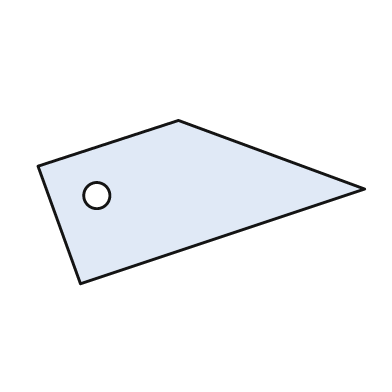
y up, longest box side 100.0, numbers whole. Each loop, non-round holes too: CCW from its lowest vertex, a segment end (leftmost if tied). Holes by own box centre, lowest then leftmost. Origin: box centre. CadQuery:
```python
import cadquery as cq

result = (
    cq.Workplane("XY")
    .moveTo(-37.0, -25.0)
    .lineTo(50.0, 4.0)
    .lineTo(-7.0, 25.0)
    .lineTo(-50.0, 11.0)
    .close()
    .moveTo(-32.0, 2.0)
    .circle(4.0)
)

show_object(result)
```